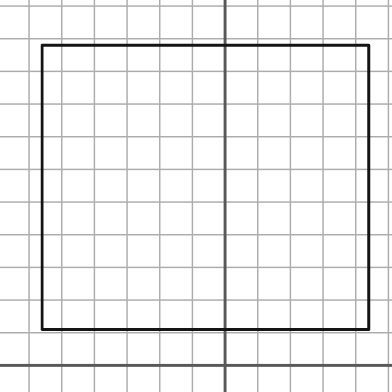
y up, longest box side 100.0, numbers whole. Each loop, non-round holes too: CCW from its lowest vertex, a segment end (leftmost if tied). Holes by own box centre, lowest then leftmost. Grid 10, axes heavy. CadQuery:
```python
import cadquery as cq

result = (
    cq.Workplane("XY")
    .moveTo(-56.0, 11.0)
    .lineTo(44.0, 11.0)
    .lineTo(44.0, 98.0)
    .lineTo(-56.0, 98.0)
    .close()
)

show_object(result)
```